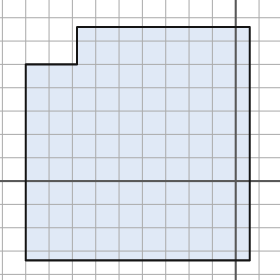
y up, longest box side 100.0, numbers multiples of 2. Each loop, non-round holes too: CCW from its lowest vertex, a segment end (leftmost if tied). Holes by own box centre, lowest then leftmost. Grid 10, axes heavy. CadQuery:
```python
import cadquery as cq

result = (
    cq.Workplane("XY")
    .moveTo(-90.0, -34.0)
    .lineTo(6.0, -34.0)
    .lineTo(6.0, 66.0)
    .lineTo(-68.0, 66.0)
    .lineTo(-68.0, 50.0)
    .lineTo(-90.0, 50.0)
    .close()
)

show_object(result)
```